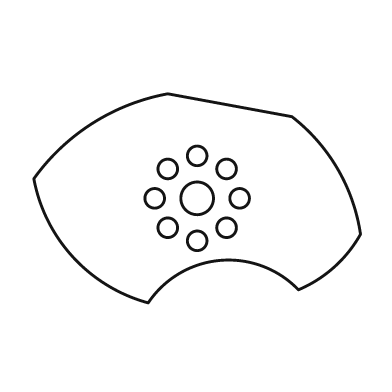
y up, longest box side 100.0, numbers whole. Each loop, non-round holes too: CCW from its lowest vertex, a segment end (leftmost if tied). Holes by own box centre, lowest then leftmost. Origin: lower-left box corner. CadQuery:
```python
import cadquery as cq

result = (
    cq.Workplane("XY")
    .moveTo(35.0, 0.0)
    .threePointArc((57.0, 13.0), (81.0, 4.0))
    .threePointArc((92.0, 11.0), (100.0, 21.0))
    .threePointArc((93.0, 41.0), (79.0, 57.0))
    .lineTo(41.0, 64.0)
    .threePointArc((18.0, 55.0), (0.0, 38.0))
    .threePointArc((12.0, 14.0), (35.0, 0.0))
    .close()
    .moveTo(50.0, 19.0)
    .circle(3.0)
    .moveTo(41.0, 23.0)
    .circle(3.0)
    .moveTo(59.0, 23.0)
    .circle(3.0)
    .moveTo(37.0, 32.0)
    .circle(3.0)
    .moveTo(50.0, 32.0)
    .circle(5.0)
    .moveTo(63.0, 32.0)
    .circle(3.0)
    .moveTo(41.0, 41.0)
    .circle(3.0)
    .moveTo(59.0, 41.0)
    .circle(3.0)
    .moveTo(50.0, 45.0)
    .circle(3.0)
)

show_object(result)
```